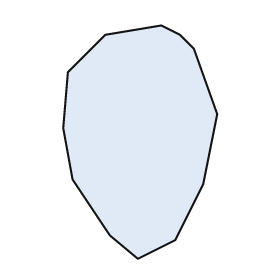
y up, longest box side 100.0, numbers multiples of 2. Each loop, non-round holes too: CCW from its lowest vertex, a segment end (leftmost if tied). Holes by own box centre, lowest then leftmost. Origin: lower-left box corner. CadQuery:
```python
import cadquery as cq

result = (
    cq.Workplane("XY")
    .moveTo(32.0, 0.0)
    .lineTo(48.0, 8.0)
    .lineTo(60.0, 32.0)
    .lineTo(66.0, 62.0)
    .lineTo(56.0, 90.0)
    .lineTo(50.0, 96.0)
    .lineTo(42.0, 100.0)
    .lineTo(18.0, 96.0)
    .lineTo(2.0, 80.0)
    .lineTo(0.0, 56.0)
    .lineTo(4.0, 34.0)
    .lineTo(20.0, 10.0)
    .close()
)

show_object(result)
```